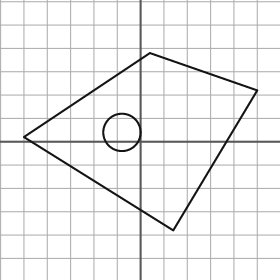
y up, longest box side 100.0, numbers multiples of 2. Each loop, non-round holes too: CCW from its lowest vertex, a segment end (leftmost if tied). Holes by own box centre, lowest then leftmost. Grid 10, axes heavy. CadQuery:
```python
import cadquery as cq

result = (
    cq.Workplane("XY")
    .moveTo(14.0, -38.0)
    .lineTo(50.0, 22.0)
    .lineTo(4.0, 38.0)
    .lineTo(-50.0, 2.0)
    .close()
    .moveTo(-8.0, 4.0)
    .circle(8.0)
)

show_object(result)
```